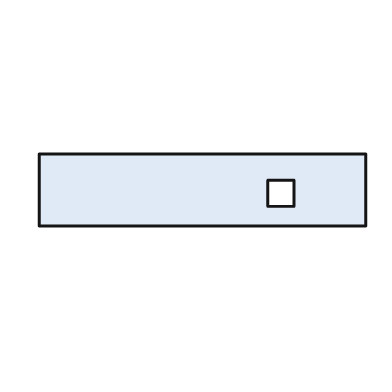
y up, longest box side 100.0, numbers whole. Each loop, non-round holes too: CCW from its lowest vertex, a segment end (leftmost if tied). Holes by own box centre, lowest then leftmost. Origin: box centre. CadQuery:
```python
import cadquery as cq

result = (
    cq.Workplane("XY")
    .moveTo(-50.0, -11.0)
    .lineTo(50.0, -11.0)
    .lineTo(50.0, 11.0)
    .lineTo(-50.0, 11.0)
    .close()
    .moveTo(20.0, -5.0)
    .lineTo(28.0, -5.0)
    .lineTo(28.0, 3.0)
    .lineTo(20.0, 3.0)
    .close()
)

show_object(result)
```